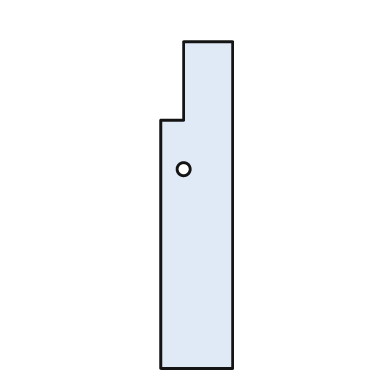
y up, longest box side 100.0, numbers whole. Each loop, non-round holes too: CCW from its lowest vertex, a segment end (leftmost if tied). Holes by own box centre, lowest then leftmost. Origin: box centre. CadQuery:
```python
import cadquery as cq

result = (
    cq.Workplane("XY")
    .moveTo(-11.0, -50.0)
    .lineTo(11.0, -50.0)
    .lineTo(11.0, 50.0)
    .lineTo(-4.0, 50.0)
    .lineTo(-4.0, 26.0)
    .lineTo(-11.0, 26.0)
    .close()
    .moveTo(-4.0, 11.0)
    .circle(2.0)
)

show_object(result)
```